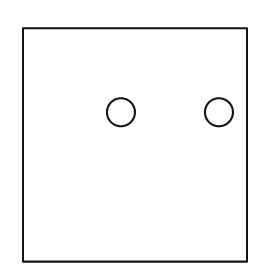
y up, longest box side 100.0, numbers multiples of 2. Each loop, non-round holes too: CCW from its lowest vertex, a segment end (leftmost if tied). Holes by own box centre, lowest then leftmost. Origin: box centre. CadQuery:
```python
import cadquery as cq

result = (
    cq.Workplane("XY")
    .moveTo(-48.0, -50.0)
    .lineTo(48.0, -50.0)
    .lineTo(48.0, 50.0)
    .lineTo(-48.0, 50.0)
    .close()
    .moveTo(-6.0, 14.0)
    .circle(6.0)
    .moveTo(36.0, 14.0)
    .circle(6.0)
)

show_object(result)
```